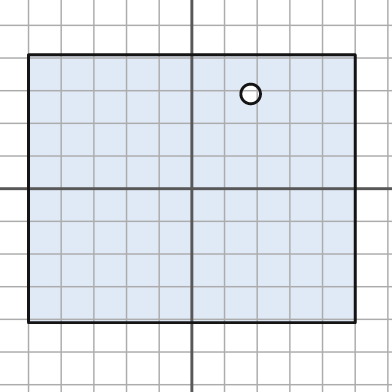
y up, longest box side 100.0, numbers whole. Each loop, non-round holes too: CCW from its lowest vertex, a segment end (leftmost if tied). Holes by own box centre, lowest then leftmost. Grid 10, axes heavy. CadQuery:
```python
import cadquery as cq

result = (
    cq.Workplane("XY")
    .moveTo(-50.0, -41.0)
    .lineTo(50.0, -41.0)
    .lineTo(50.0, 41.0)
    .lineTo(-50.0, 41.0)
    .close()
    .moveTo(18.0, 29.0)
    .circle(3.0)
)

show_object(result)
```